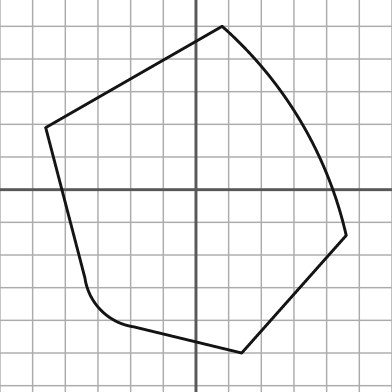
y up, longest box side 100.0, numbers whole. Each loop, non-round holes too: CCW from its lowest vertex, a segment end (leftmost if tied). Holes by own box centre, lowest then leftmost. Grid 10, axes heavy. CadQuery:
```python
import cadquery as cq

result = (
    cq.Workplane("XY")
    .moveTo(14.0, -50.0)
    .lineTo(46.0, -14.0)
    .threePointArc((32.0, 21.0), (8.0, 50.0))
    .lineTo(-46.0, 19.0)
    .lineTo(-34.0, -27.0)
    .threePointArc((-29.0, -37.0), (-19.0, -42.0))
    .close()
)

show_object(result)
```